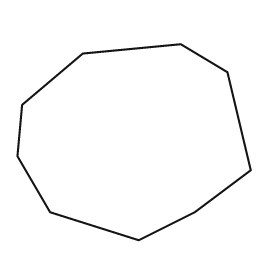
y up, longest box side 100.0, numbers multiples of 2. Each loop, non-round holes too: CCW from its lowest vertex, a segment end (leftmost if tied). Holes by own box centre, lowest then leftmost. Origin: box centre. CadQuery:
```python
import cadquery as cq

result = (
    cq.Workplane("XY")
    .moveTo(2.0, -42.0)
    .lineTo(26.0, -30.0)
    .lineTo(50.0, -12.0)
    .lineTo(40.0, 30.0)
    .lineTo(20.0, 42.0)
    .lineTo(-22.0, 38.0)
    .lineTo(-48.0, 16.0)
    .lineTo(-50.0, -6.0)
    .lineTo(-36.0, -30.0)
    .close()
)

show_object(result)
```